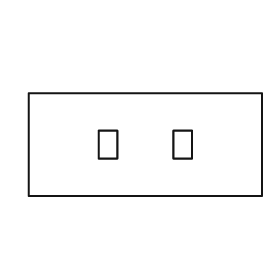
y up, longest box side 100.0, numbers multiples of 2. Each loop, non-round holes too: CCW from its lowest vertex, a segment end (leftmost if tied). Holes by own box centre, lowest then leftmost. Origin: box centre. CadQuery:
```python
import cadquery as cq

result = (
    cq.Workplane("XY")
    .moveTo(-50.0, -22.0)
    .lineTo(50.0, -22.0)
    .lineTo(50.0, 22.0)
    .lineTo(-50.0, 22.0)
    .close()
    .moveTo(-20.0, -6.0)
    .lineTo(-12.0, -6.0)
    .lineTo(-12.0, 6.0)
    .lineTo(-20.0, 6.0)
    .close()
    .moveTo(12.0, -6.0)
    .lineTo(20.0, -6.0)
    .lineTo(20.0, 6.0)
    .lineTo(12.0, 6.0)
    .close()
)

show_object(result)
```